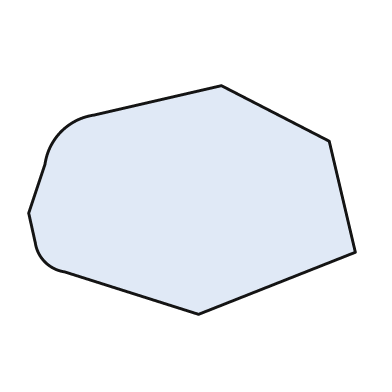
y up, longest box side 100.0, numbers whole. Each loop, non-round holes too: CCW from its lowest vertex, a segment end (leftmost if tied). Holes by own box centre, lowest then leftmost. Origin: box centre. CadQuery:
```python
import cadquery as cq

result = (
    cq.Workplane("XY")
    .moveTo(2.0, -35.0)
    .lineTo(50.0, -16.0)
    .lineTo(42.0, 18.0)
    .lineTo(9.0, 35.0)
    .lineTo(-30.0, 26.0)
    .threePointArc((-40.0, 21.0), (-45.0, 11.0))
    .lineTo(-50.0, -4.0)
    .lineTo(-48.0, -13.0)
    .threePointArc((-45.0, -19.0), (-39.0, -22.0))
    .close()
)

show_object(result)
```